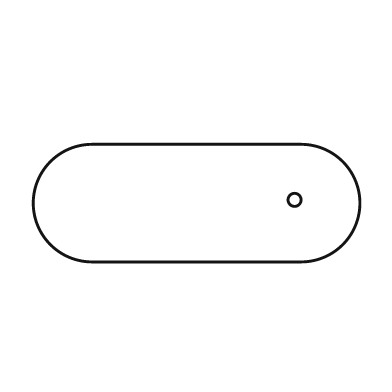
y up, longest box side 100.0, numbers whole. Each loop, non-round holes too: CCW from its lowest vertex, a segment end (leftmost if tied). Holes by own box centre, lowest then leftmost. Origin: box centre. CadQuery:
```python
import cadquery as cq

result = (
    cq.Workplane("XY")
    .moveTo(-32.0, -18.0)
    .lineTo(32.0, -18.0)
    .threePointArc((50.0, 0.0), (32.0, 18.0))
    .lineTo(-32.0, 18.0)
    .threePointArc((-50.0, 0.0), (-32.0, -18.0))
    .close()
    .moveTo(30.0, 1.0)
    .circle(2.0)
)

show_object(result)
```